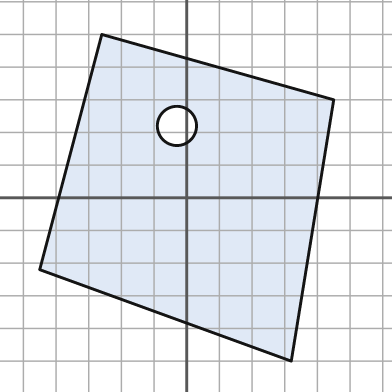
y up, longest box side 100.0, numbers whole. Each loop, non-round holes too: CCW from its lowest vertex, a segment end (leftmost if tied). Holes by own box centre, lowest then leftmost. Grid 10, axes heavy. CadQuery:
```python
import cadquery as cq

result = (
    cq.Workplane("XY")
    .moveTo(32.0, -50.0)
    .lineTo(45.0, 30.0)
    .lineTo(-26.0, 50.0)
    .lineTo(-45.0, -22.0)
    .close()
    .moveTo(-3.0, 22.0)
    .circle(6.0)
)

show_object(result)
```